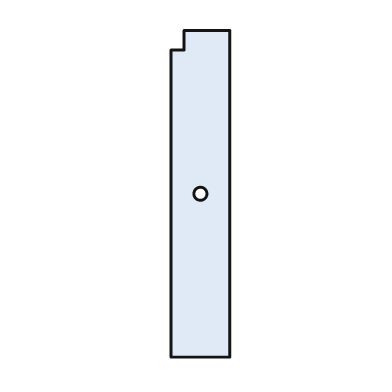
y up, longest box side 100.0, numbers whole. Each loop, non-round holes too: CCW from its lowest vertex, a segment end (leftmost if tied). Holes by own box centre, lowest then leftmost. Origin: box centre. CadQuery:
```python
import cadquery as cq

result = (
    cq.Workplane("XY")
    .moveTo(-9.0, -50.0)
    .lineTo(9.0, -50.0)
    .lineTo(9.0, 50.0)
    .lineTo(-5.0, 50.0)
    .lineTo(-5.0, 44.0)
    .lineTo(-9.0, 44.0)
    .close()
    .moveTo(0.0, 0.0)
    .circle(2.0)
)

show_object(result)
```